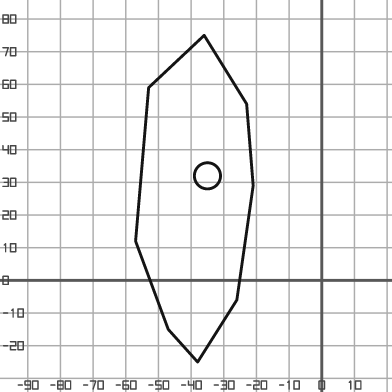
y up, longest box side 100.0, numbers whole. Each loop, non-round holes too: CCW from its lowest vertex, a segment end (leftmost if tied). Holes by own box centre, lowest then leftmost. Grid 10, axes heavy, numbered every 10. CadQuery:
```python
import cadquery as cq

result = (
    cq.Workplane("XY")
    .moveTo(-38.0, -25.0)
    .lineTo(-26.0, -6.0)
    .lineTo(-21.0, 29.0)
    .lineTo(-23.0, 54.0)
    .lineTo(-36.0, 75.0)
    .lineTo(-53.0, 59.0)
    .lineTo(-57.0, 12.0)
    .lineTo(-47.0, -15.0)
    .close()
    .moveTo(-35.0, 32.0)
    .circle(4.0)
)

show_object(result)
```